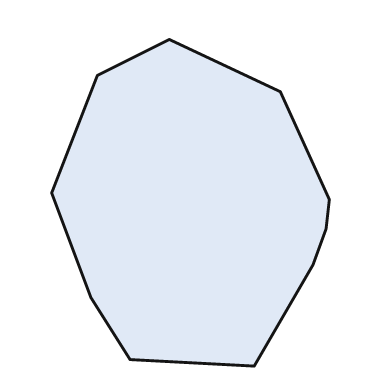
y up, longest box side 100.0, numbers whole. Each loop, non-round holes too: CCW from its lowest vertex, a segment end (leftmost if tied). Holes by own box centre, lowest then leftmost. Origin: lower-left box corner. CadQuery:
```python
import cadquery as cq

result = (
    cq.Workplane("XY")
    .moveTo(62.0, 0.0)
    .lineTo(80.0, 31.0)
    .lineTo(84.0, 42.0)
    .lineTo(85.0, 51.0)
    .lineTo(70.0, 84.0)
    .lineTo(36.0, 100.0)
    .lineTo(14.0, 89.0)
    .lineTo(0.0, 53.0)
    .lineTo(12.0, 21.0)
    .lineTo(24.0, 2.0)
    .close()
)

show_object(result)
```